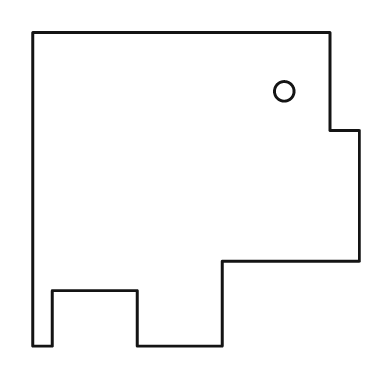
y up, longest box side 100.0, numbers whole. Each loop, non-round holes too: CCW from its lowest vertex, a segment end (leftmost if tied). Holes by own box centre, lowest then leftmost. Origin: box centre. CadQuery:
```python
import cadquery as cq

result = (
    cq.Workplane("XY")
    .moveTo(-50.0, -48.0)
    .lineTo(-44.0, -48.0)
    .lineTo(-44.0, -31.0)
    .lineTo(-18.0, -31.0)
    .lineTo(-18.0, -48.0)
    .lineTo(8.0, -48.0)
    .lineTo(8.0, -22.0)
    .lineTo(50.0, -22.0)
    .lineTo(50.0, 18.0)
    .lineTo(41.0, 18.0)
    .lineTo(41.0, 48.0)
    .lineTo(-50.0, 48.0)
    .close()
    .moveTo(27.0, 30.0)
    .circle(3.0)
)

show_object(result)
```